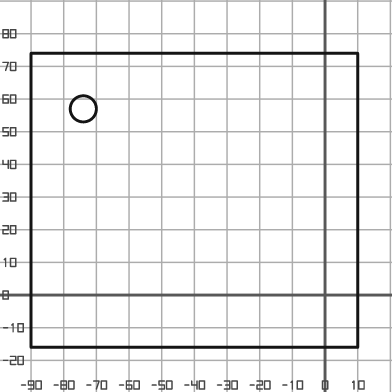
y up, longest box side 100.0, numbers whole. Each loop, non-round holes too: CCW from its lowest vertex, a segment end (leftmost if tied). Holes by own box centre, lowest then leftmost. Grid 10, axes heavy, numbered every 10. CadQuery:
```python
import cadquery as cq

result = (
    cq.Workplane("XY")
    .moveTo(-90.0, -16.0)
    .lineTo(10.0, -16.0)
    .lineTo(10.0, 74.0)
    .lineTo(-90.0, 74.0)
    .close()
    .moveTo(-74.0, 57.0)
    .circle(4.0)
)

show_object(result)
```